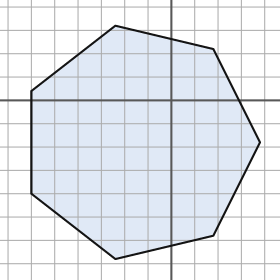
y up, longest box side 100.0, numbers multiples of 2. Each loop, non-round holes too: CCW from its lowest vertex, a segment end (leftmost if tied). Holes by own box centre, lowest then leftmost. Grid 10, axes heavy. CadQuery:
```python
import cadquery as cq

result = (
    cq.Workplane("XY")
    .moveTo(-24.0, -68.0)
    .lineTo(18.0, -58.0)
    .lineTo(38.0, -18.0)
    .lineTo(18.0, 22.0)
    .lineTo(-24.0, 32.0)
    .lineTo(-60.0, 4.0)
    .lineTo(-60.0, -40.0)
    .close()
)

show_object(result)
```